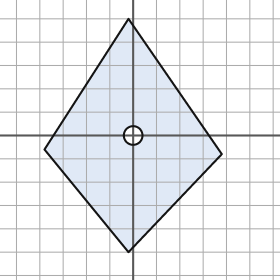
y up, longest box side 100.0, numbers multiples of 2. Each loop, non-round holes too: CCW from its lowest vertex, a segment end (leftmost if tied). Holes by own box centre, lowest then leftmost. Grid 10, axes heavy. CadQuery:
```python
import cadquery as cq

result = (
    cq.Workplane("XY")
    .moveTo(-2.0, -50.0)
    .lineTo(38.0, -8.0)
    .lineTo(-2.0, 50.0)
    .lineTo(-38.0, -6.0)
    .close()
    .moveTo(0.0, 0.0)
    .circle(4.0)
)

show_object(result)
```